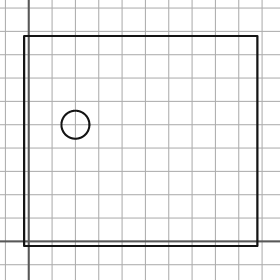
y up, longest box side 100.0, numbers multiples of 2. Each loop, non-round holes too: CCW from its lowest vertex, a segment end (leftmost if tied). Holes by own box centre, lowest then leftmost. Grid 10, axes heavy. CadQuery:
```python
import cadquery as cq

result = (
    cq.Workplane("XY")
    .moveTo(-2.0, -2.0)
    .lineTo(98.0, -2.0)
    .lineTo(98.0, 88.0)
    .lineTo(-2.0, 88.0)
    .close()
    .moveTo(20.0, 50.0)
    .circle(6.0)
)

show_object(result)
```